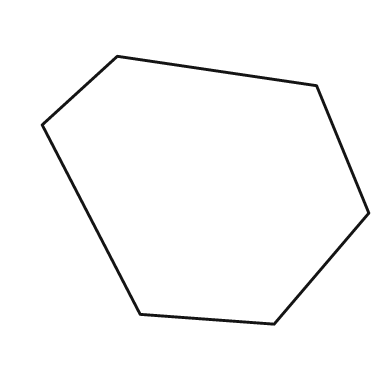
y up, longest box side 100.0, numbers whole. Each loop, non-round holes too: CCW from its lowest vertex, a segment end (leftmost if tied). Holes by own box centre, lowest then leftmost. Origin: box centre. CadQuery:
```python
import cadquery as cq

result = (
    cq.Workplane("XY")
    .moveTo(21.0, -41.0)
    .lineTo(50.0, -7.0)
    .lineTo(34.0, 32.0)
    .lineTo(-27.0, 41.0)
    .lineTo(-50.0, 20.0)
    .lineTo(-20.0, -38.0)
    .close()
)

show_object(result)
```